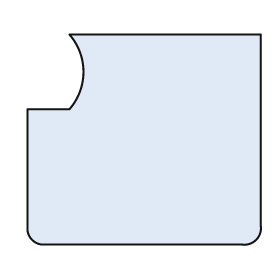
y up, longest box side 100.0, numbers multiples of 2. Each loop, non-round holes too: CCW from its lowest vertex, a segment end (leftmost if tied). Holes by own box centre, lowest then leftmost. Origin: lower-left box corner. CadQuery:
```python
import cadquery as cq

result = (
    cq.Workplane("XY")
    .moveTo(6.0, 0.0)
    .lineTo(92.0, 0.0)
    .threePointArc((98.0, 2.0), (100.0, 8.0))
    .lineTo(100.0, 90.0)
    .lineTo(18.0, 90.0)
    .threePointArc((24.0, 74.0), (18.0, 58.0))
    .lineTo(0.0, 58.0)
    .lineTo(0.0, 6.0)
    .threePointArc((2.0, 2.0), (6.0, 0.0))
    .close()
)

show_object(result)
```